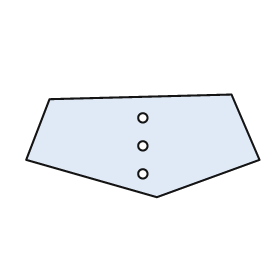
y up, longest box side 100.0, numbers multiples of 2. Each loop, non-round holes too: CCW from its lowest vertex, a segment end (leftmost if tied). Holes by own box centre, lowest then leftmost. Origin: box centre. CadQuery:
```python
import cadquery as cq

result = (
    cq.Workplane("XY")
    .moveTo(6.0, -22.0)
    .lineTo(50.0, -6.0)
    .lineTo(38.0, 22.0)
    .lineTo(-40.0, 20.0)
    .lineTo(-50.0, -6.0)
    .close()
    .moveTo(0.0, -12.0)
    .circle(2.0)
    .moveTo(0.0, 0.0)
    .circle(2.0)
    .moveTo(0.0, 12.0)
    .circle(2.0)
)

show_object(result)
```